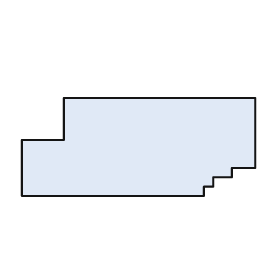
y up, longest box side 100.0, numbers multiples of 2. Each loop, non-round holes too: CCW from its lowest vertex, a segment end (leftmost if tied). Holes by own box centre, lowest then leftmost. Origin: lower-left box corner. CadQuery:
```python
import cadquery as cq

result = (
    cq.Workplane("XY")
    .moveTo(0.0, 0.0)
    .lineTo(78.0, 0.0)
    .lineTo(78.0, 4.0)
    .lineTo(82.0, 4.0)
    .lineTo(82.0, 8.0)
    .lineTo(90.0, 8.0)
    .lineTo(90.0, 12.0)
    .lineTo(100.0, 12.0)
    .lineTo(100.0, 42.0)
    .lineTo(18.0, 42.0)
    .lineTo(18.0, 24.0)
    .lineTo(0.0, 24.0)
    .close()
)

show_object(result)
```